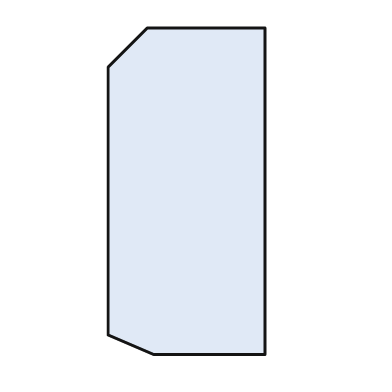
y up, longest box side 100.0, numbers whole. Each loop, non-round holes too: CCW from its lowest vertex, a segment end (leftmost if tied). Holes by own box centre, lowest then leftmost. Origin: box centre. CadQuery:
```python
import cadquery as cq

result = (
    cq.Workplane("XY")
    .moveTo(-10.0, -50.0)
    .lineTo(24.0, -50.0)
    .lineTo(24.0, 50.0)
    .lineTo(-12.0, 50.0)
    .lineTo(-24.0, 38.0)
    .lineTo(-24.0, -44.0)
    .close()
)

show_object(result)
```